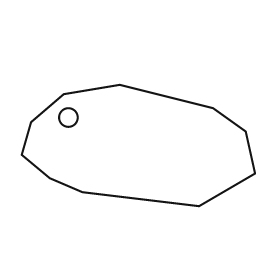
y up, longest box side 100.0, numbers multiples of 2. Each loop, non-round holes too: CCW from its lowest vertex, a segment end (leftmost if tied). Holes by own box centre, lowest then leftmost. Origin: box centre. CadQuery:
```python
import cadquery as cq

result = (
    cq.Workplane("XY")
    .moveTo(26.0, -26.0)
    .lineTo(50.0, -12.0)
    .lineTo(46.0, 6.0)
    .lineTo(32.0, 16.0)
    .lineTo(-8.0, 26.0)
    .lineTo(-32.0, 22.0)
    .lineTo(-46.0, 10.0)
    .lineTo(-50.0, -4.0)
    .lineTo(-38.0, -14.0)
    .lineTo(-24.0, -20.0)
    .close()
    .moveTo(-30.0, 12.0)
    .circle(4.0)
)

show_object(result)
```